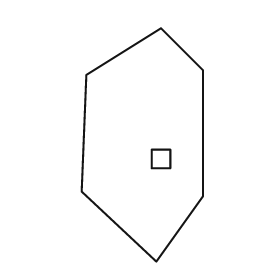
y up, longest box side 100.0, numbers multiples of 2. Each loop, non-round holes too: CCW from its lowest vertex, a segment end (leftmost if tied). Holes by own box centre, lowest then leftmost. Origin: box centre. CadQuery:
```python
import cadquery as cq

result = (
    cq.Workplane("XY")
    .moveTo(6.0, -50.0)
    .lineTo(26.0, -22.0)
    .lineTo(26.0, 32.0)
    .lineTo(8.0, 50.0)
    .lineTo(-24.0, 30.0)
    .lineTo(-26.0, -20.0)
    .close()
    .moveTo(4.0, -10.0)
    .lineTo(12.0, -10.0)
    .lineTo(12.0, -2.0)
    .lineTo(4.0, -2.0)
    .close()
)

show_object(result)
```